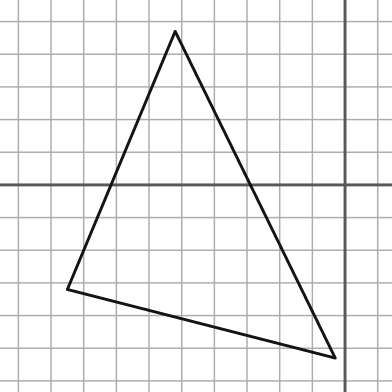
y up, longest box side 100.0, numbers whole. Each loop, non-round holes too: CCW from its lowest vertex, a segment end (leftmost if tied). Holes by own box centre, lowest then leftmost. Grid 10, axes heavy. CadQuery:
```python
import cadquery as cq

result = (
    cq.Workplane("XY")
    .moveTo(-3.0, -53.0)
    .lineTo(-52.0, 47.0)
    .lineTo(-85.0, -32.0)
    .close()
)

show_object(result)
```